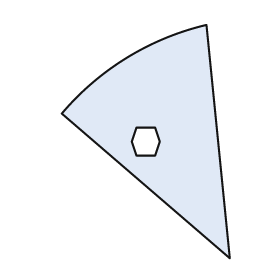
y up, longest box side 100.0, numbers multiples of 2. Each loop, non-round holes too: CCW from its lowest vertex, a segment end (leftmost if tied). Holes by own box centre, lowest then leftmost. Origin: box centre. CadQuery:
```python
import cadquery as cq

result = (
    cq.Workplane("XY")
    .moveTo(36.0, -50.0)
    .lineTo(26.0, 50.0)
    .threePointArc((-8.0, 36.0), (-36.0, 12.0))
    .close()
    .moveTo(-4.0, -6.0)
    .lineTo(4.0, -6.0)
    .lineTo(6.0, 0.0)
    .lineTo(4.0, 6.0)
    .lineTo(-4.0, 6.0)
    .lineTo(-6.0, 0.0)
    .close()
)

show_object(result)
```